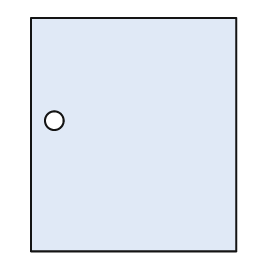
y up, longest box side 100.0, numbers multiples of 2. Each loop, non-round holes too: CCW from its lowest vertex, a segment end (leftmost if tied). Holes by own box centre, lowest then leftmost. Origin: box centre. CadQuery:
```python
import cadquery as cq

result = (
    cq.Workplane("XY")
    .moveTo(-44.0, -50.0)
    .lineTo(44.0, -50.0)
    .lineTo(44.0, 50.0)
    .lineTo(-44.0, 50.0)
    .close()
    .moveTo(-34.0, 6.0)
    .circle(4.0)
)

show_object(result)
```